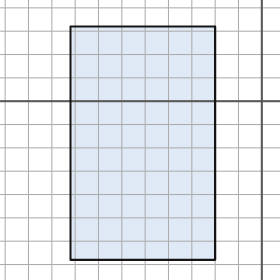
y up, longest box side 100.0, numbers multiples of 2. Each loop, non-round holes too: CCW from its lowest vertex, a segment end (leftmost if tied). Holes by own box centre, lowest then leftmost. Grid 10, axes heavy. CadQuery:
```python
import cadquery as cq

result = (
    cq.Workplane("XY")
    .moveTo(-82.0, -68.0)
    .lineTo(-20.0, -68.0)
    .lineTo(-20.0, 32.0)
    .lineTo(-82.0, 32.0)
    .close()
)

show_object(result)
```